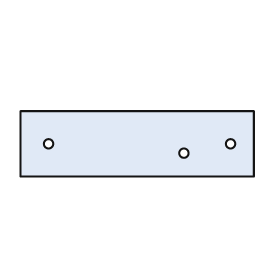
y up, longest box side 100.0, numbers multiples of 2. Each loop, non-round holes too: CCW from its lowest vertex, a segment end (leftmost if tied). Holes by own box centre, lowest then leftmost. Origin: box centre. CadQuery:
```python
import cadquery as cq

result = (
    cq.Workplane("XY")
    .moveTo(-50.0, -14.0)
    .lineTo(50.0, -14.0)
    .lineTo(50.0, 14.0)
    .lineTo(-50.0, 14.0)
    .close()
    .moveTo(20.0, -4.0)
    .circle(2.0)
    .moveTo(-38.0, 0.0)
    .circle(2.0)
    .moveTo(40.0, 0.0)
    .circle(2.0)
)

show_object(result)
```